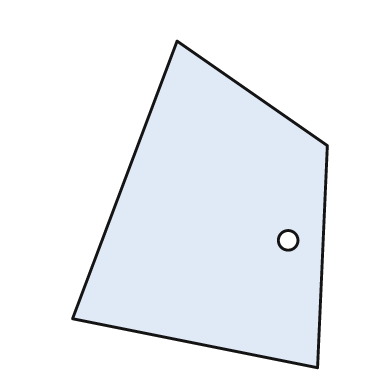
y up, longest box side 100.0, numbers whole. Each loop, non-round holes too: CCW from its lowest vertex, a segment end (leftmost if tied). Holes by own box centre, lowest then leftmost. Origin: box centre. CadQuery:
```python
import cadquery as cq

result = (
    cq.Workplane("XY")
    .moveTo(36.0, -50.0)
    .lineTo(39.0, 18.0)
    .lineTo(-7.0, 50.0)
    .lineTo(-39.0, -35.0)
    .close()
    .moveTo(27.0, -11.0)
    .circle(3.0)
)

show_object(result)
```